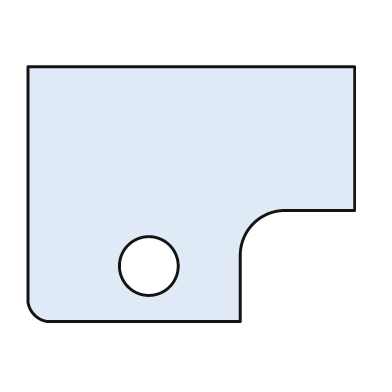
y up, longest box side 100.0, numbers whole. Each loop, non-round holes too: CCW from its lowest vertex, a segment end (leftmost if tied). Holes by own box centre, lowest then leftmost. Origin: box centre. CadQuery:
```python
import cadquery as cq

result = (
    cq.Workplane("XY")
    .moveTo(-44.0, -39.0)
    .lineTo(15.0, -39.0)
    .lineTo(15.0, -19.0)
    .threePointArc((19.0, -9.0), (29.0, -5.0))
    .lineTo(50.0, -5.0)
    .lineTo(50.0, 39.0)
    .lineTo(-50.0, 39.0)
    .lineTo(-50.0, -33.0)
    .threePointArc((-48.0, -37.0), (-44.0, -39.0))
    .close()
    .moveTo(-13.0, -22.0)
    .circle(9.0)
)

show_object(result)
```